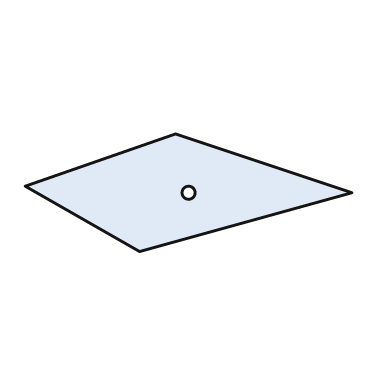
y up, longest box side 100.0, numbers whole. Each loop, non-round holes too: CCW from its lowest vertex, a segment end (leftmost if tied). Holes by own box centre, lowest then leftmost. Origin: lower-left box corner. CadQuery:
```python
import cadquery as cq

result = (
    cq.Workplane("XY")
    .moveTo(35.0, 0.0)
    .lineTo(100.0, 18.0)
    .lineTo(46.0, 36.0)
    .lineTo(0.0, 20.0)
    .close()
    .moveTo(50.0, 18.0)
    .circle(2.0)
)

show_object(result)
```